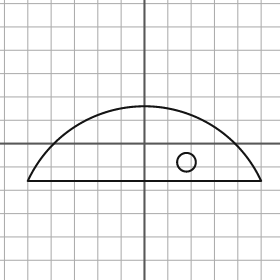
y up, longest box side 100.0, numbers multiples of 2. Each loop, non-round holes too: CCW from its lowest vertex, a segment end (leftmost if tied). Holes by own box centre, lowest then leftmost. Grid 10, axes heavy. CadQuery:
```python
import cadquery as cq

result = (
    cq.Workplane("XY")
    .moveTo(-50.0, -16.0)
    .lineTo(50.0, -16.0)
    .threePointArc((0.0, 16.0), (-50.0, -16.0))
    .close()
    .moveTo(18.0, -8.0)
    .circle(4.0)
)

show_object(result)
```